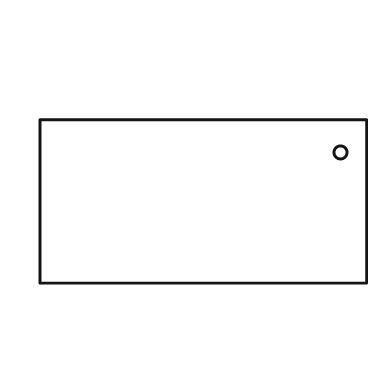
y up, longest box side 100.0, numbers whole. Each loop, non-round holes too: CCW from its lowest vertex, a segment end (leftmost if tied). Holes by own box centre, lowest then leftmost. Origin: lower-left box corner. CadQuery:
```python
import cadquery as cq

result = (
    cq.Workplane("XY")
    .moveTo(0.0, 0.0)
    .lineTo(100.0, 0.0)
    .lineTo(100.0, 50.0)
    .lineTo(0.0, 50.0)
    .close()
    .moveTo(92.0, 40.0)
    .circle(2.0)
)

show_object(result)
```